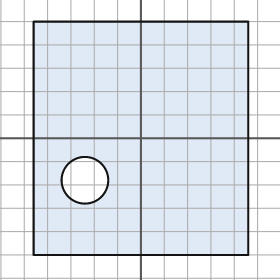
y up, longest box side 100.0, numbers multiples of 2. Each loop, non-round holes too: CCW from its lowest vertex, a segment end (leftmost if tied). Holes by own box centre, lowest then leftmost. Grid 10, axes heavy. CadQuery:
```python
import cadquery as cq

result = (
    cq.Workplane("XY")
    .moveTo(-46.0, -50.0)
    .lineTo(46.0, -50.0)
    .lineTo(46.0, 50.0)
    .lineTo(-46.0, 50.0)
    .close()
    .moveTo(-24.0, -18.0)
    .circle(10.0)
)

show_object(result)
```